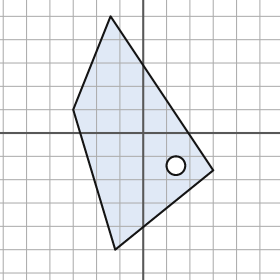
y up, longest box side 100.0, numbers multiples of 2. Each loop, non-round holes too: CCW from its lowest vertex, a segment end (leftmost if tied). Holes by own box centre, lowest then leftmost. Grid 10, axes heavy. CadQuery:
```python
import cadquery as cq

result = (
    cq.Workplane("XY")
    .moveTo(-12.0, -50.0)
    .lineTo(30.0, -16.0)
    .lineTo(-14.0, 50.0)
    .lineTo(-30.0, 10.0)
    .close()
    .moveTo(14.0, -14.0)
    .circle(4.0)
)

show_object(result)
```